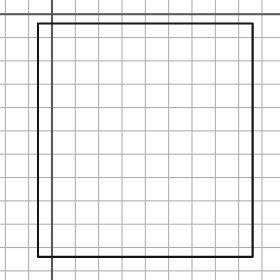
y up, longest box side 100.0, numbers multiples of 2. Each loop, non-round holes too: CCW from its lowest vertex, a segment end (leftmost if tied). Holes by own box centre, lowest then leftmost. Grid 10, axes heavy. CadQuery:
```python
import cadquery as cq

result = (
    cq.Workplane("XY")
    .moveTo(-6.0, -104.0)
    .lineTo(86.0, -104.0)
    .lineTo(86.0, -4.0)
    .lineTo(-6.0, -4.0)
    .close()
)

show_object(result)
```